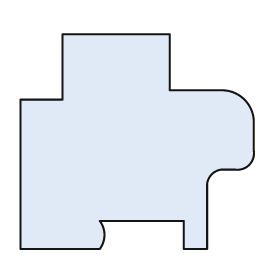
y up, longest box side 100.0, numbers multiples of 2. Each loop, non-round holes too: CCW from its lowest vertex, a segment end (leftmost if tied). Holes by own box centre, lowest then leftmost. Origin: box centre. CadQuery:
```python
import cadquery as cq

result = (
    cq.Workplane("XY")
    .moveTo(-50.0, -46.0)
    .lineTo(-16.0, -46.0)
    .threePointArc((-14.0, -40.0), (-16.0, -34.0))
    .lineTo(20.0, -34.0)
    .lineTo(20.0, -46.0)
    .lineTo(30.0, -46.0)
    .lineTo(30.0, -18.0)
    .threePointArc((32.0, -14.0), (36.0, -12.0))
    .lineTo(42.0, -12.0)
    .threePointArc((48.0, -10.0), (50.0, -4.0))
    .lineTo(50.0, 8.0)
    .threePointArc((46.0, 18.0), (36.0, 22.0))
    .lineTo(14.0, 22.0)
    .lineTo(14.0, 46.0)
    .lineTo(-32.0, 46.0)
    .lineTo(-32.0, 18.0)
    .lineTo(-50.0, 18.0)
    .close()
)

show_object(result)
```